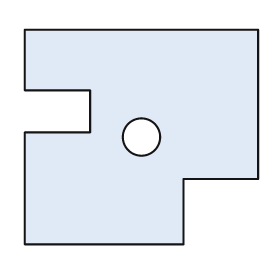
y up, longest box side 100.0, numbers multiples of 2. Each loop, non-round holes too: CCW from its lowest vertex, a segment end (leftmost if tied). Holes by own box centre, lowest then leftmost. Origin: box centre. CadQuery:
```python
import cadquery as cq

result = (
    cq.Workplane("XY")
    .moveTo(-50.0, -46.0)
    .lineTo(18.0, -46.0)
    .lineTo(18.0, -18.0)
    .lineTo(50.0, -18.0)
    .lineTo(50.0, 46.0)
    .lineTo(-50.0, 46.0)
    .lineTo(-50.0, 20.0)
    .lineTo(-22.0, 20.0)
    .lineTo(-22.0, 2.0)
    .lineTo(-50.0, 2.0)
    .close()
    .moveTo(0.0, 0.0)
    .circle(8.0)
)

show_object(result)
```